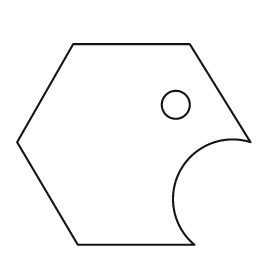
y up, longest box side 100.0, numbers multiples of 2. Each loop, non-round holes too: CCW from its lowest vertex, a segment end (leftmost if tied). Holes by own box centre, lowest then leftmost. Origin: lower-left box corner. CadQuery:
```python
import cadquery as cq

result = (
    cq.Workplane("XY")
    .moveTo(26.0, 0.0)
    .lineTo(76.0, 0.0)
    .threePointArc((70.0, 32.0), (100.0, 44.0))
    .lineTo(74.0, 86.0)
    .lineTo(24.0, 86.0)
    .lineTo(0.0, 44.0)
    .close()
    .moveTo(68.0, 60.0)
    .circle(6.0)
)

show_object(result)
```